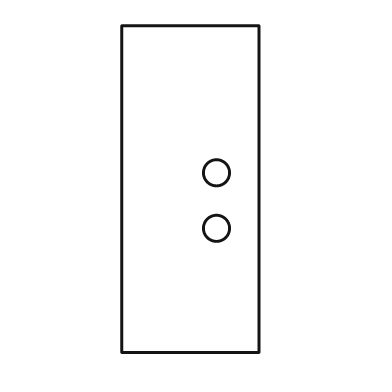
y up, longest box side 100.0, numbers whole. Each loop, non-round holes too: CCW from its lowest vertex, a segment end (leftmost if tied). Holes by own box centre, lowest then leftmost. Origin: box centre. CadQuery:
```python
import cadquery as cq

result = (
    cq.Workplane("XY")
    .moveTo(-21.0, -50.0)
    .lineTo(21.0, -50.0)
    .lineTo(21.0, 50.0)
    .lineTo(-21.0, 50.0)
    .close()
    .moveTo(8.0, -12.0)
    .circle(4.0)
    .moveTo(8.0, 5.0)
    .circle(4.0)
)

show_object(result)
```